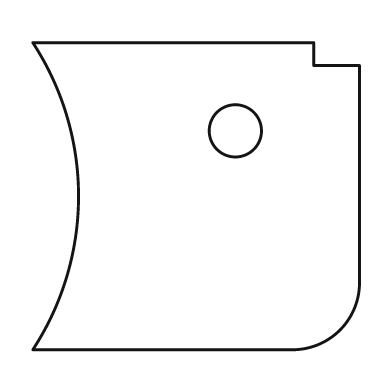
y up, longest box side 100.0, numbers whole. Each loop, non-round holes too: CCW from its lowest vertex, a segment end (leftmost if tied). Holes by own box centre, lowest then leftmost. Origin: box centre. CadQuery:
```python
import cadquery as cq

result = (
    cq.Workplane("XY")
    .moveTo(-50.0, -47.0)
    .lineTo(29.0, -47.0)
    .threePointArc((44.0, -41.0), (50.0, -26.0))
    .lineTo(50.0, 40.0)
    .lineTo(36.0, 40.0)
    .lineTo(36.0, 47.0)
    .lineTo(-50.0, 47.0)
    .threePointArc((-36.0, 0.0), (-50.0, -47.0))
    .close()
    .moveTo(12.0, 20.0)
    .circle(8.0)
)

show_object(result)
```